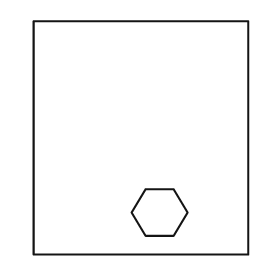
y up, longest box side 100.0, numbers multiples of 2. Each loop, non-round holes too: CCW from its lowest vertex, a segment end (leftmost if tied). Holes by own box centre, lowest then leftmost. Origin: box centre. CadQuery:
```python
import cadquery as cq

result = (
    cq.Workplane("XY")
    .moveTo(-46.0, -50.0)
    .lineTo(46.0, -50.0)
    .lineTo(46.0, 50.0)
    .lineTo(-46.0, 50.0)
    .close()
    .moveTo(2.0, -42.0)
    .lineTo(14.0, -42.0)
    .lineTo(20.0, -32.0)
    .lineTo(14.0, -22.0)
    .lineTo(2.0, -22.0)
    .lineTo(-4.0, -32.0)
    .close()
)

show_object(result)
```